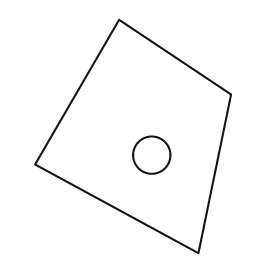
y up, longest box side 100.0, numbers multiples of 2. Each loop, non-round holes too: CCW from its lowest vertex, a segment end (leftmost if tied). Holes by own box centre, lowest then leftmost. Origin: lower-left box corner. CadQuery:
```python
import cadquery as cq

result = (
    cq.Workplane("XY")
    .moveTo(70.0, 0.0)
    .lineTo(84.0, 68.0)
    .lineTo(36.0, 100.0)
    .lineTo(0.0, 38.0)
    .close()
    .moveTo(50.0, 42.0)
    .circle(8.0)
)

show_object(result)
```